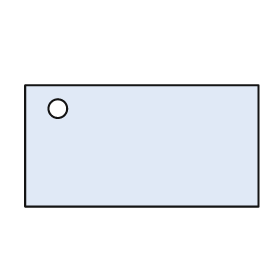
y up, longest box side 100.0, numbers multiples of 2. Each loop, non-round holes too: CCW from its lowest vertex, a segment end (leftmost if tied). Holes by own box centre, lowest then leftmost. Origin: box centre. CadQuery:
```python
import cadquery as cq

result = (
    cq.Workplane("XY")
    .moveTo(-50.0, -26.0)
    .lineTo(50.0, -26.0)
    .lineTo(50.0, 26.0)
    .lineTo(-50.0, 26.0)
    .close()
    .moveTo(-36.0, 16.0)
    .circle(4.0)
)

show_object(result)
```